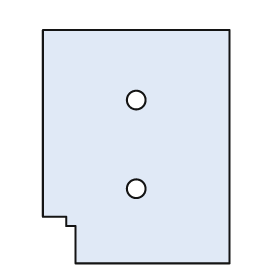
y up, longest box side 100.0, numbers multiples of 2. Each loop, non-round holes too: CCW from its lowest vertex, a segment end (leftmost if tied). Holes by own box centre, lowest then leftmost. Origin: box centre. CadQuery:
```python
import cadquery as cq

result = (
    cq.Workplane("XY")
    .moveTo(-26.0, -50.0)
    .lineTo(40.0, -50.0)
    .lineTo(40.0, 50.0)
    .lineTo(-40.0, 50.0)
    .lineTo(-40.0, -30.0)
    .lineTo(-30.0, -30.0)
    .lineTo(-30.0, -34.0)
    .lineTo(-26.0, -34.0)
    .close()
    .moveTo(0.0, -18.0)
    .circle(4.0)
    .moveTo(0.0, 20.0)
    .circle(4.0)
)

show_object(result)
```